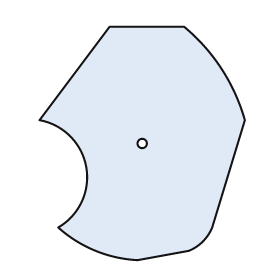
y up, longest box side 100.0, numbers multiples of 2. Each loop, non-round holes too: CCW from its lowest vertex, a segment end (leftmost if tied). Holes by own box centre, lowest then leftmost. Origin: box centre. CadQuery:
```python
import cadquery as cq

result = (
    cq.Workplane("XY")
    .moveTo(-2.0, -50.0)
    .lineTo(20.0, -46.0)
    .threePointArc((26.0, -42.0), (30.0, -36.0))
    .lineTo(44.0, 10.0)
    .threePointArc((34.0, 32.0), (18.0, 50.0))
    .lineTo(-14.0, 50.0)
    .lineTo(-44.0, 10.0)
    .threePointArc((-24.0, -10.0), (-36.0, -36.0))
    .threePointArc((-20.0, -46.0), (-2.0, -50.0))
    .close()
    .moveTo(0.0, 0.0)
    .circle(2.0)
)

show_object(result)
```